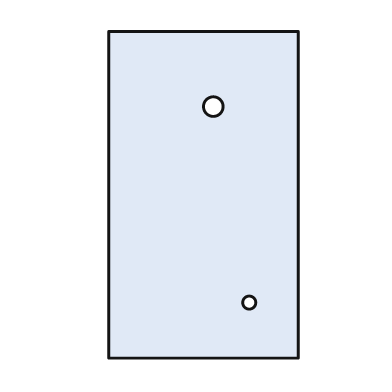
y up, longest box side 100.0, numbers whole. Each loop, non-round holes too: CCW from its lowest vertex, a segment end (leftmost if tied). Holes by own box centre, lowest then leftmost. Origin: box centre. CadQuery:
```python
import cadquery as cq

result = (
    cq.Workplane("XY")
    .moveTo(-29.0, -50.0)
    .lineTo(29.0, -50.0)
    .lineTo(29.0, 50.0)
    .lineTo(-29.0, 50.0)
    .close()
    .moveTo(14.0, -33.0)
    .circle(2.0)
    .moveTo(3.0, 27.0)
    .circle(3.0)
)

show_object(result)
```